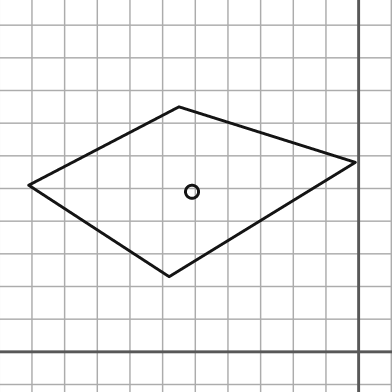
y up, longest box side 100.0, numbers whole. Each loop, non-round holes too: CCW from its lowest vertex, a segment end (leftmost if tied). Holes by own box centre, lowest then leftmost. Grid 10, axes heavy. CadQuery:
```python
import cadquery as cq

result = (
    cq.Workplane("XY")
    .moveTo(-58.0, 23.0)
    .lineTo(-1.0, 58.0)
    .lineTo(-55.0, 75.0)
    .lineTo(-101.0, 51.0)
    .close()
    .moveTo(-51.0, 49.0)
    .circle(2.0)
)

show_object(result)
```